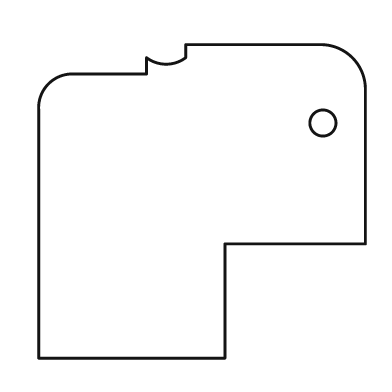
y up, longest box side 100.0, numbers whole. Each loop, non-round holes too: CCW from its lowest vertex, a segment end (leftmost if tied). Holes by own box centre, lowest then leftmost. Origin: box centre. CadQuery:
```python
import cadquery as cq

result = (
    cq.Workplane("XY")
    .moveTo(-50.0, -48.0)
    .lineTo(7.0, -48.0)
    .lineTo(7.0, -13.0)
    .lineTo(50.0, -13.0)
    .lineTo(50.0, 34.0)
    .threePointArc((46.0, 44.0), (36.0, 48.0))
    .lineTo(-5.0, 48.0)
    .lineTo(-5.0, 44.0)
    .threePointArc((-11.0, 42.0), (-17.0, 44.0))
    .lineTo(-17.0, 39.0)
    .lineTo(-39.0, 39.0)
    .threePointArc((-47.0, 36.0), (-50.0, 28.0))
    .close()
    .moveTo(37.0, 24.0)
    .circle(4.0)
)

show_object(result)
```